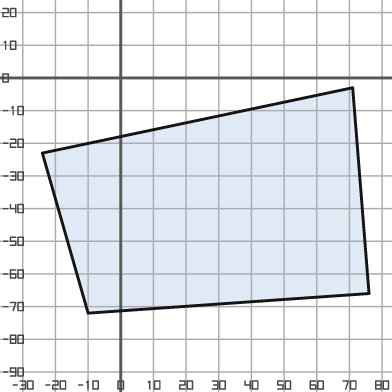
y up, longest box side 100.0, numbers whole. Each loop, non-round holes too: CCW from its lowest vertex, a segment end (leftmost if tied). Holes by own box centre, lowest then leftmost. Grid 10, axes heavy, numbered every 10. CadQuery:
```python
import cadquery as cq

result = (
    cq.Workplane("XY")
    .moveTo(-10.0, -72.0)
    .lineTo(76.0, -66.0)
    .lineTo(71.0, -3.0)
    .lineTo(-24.0, -23.0)
    .close()
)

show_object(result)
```